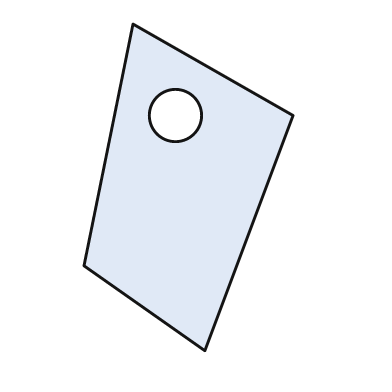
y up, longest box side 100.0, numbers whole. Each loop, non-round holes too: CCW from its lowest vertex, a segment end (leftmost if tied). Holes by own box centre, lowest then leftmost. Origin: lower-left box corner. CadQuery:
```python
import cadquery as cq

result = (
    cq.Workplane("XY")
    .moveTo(37.0, 0.0)
    .lineTo(64.0, 72.0)
    .lineTo(15.0, 100.0)
    .lineTo(0.0, 26.0)
    .close()
    .moveTo(28.0, 72.0)
    .circle(8.0)
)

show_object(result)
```